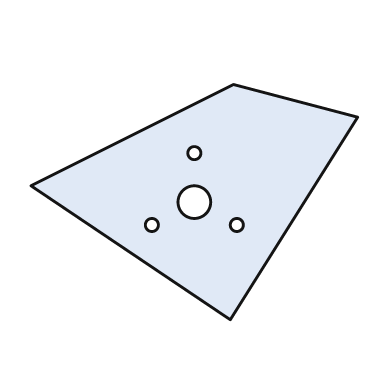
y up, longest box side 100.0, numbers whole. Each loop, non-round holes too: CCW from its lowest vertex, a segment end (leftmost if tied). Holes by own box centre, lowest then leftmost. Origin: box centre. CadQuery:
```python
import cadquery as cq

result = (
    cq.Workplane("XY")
    .moveTo(11.0, -36.0)
    .lineTo(50.0, 26.0)
    .lineTo(12.0, 36.0)
    .lineTo(-50.0, 5.0)
    .close()
    .moveTo(-13.0, -7.0)
    .circle(2.0)
    .moveTo(13.0, -7.0)
    .circle(2.0)
    .moveTo(0.0, 0.0)
    .circle(5.0)
    .moveTo(0.0, 15.0)
    .circle(2.0)
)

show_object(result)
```